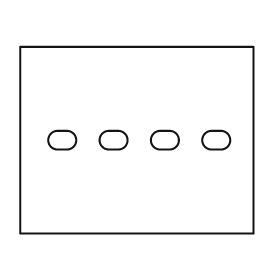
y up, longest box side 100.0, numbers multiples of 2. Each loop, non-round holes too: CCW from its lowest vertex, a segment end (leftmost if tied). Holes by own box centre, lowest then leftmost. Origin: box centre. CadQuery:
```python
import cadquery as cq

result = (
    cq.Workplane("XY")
    .moveTo(-50.0, -40.0)
    .lineTo(50.0, -40.0)
    .lineTo(50.0, 40.0)
    .lineTo(-50.0, 40.0)
    .close()
    .moveTo(-34.0, -4.0)
    .lineTo(-30.0, -4.0)
    .threePointArc((-26.0, 0.0), (-30.0, 4.0))
    .lineTo(-34.0, 4.0)
    .threePointArc((-38.0, 0.0), (-34.0, -4.0))
    .close()
    .moveTo(-12.0, -4.0)
    .lineTo(-8.0, -4.0)
    .threePointArc((-4.0, 0.0), (-8.0, 4.0))
    .lineTo(-12.0, 4.0)
    .threePointArc((-16.0, 0.0), (-12.0, -4.0))
    .close()
    .moveTo(10.0, -4.0)
    .lineTo(14.0, -4.0)
    .threePointArc((18.0, 0.0), (14.0, 4.0))
    .lineTo(10.0, 4.0)
    .threePointArc((6.0, 0.0), (10.0, -4.0))
    .close()
    .moveTo(32.0, -4.0)
    .lineTo(36.0, -4.0)
    .threePointArc((40.0, 0.0), (36.0, 4.0))
    .lineTo(32.0, 4.0)
    .threePointArc((28.0, 0.0), (32.0, -4.0))
    .close()
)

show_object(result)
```